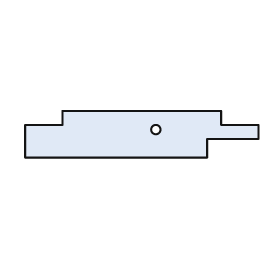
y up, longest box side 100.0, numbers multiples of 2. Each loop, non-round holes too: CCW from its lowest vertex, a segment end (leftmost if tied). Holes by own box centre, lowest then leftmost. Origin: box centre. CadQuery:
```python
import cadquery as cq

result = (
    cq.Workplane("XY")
    .moveTo(-50.0, -10.0)
    .lineTo(28.0, -10.0)
    .lineTo(28.0, -2.0)
    .lineTo(50.0, -2.0)
    .lineTo(50.0, 4.0)
    .lineTo(34.0, 4.0)
    .lineTo(34.0, 10.0)
    .lineTo(-34.0, 10.0)
    .lineTo(-34.0, 4.0)
    .lineTo(-50.0, 4.0)
    .close()
    .moveTo(6.0, 2.0)
    .circle(2.0)
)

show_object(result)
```